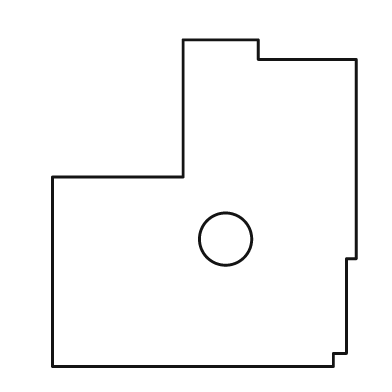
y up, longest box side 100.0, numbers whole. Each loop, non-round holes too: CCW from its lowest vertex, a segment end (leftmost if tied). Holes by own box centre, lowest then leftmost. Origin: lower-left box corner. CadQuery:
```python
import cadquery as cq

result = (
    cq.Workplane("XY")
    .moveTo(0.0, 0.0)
    .lineTo(86.0, 0.0)
    .lineTo(86.0, 4.0)
    .lineTo(90.0, 4.0)
    .lineTo(90.0, 33.0)
    .lineTo(93.0, 33.0)
    .lineTo(93.0, 94.0)
    .lineTo(63.0, 94.0)
    .lineTo(63.0, 100.0)
    .lineTo(40.0, 100.0)
    .lineTo(40.0, 58.0)
    .lineTo(0.0, 58.0)
    .close()
    .moveTo(53.0, 39.0)
    .circle(8.0)
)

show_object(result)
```